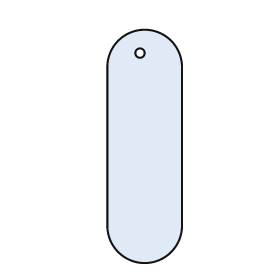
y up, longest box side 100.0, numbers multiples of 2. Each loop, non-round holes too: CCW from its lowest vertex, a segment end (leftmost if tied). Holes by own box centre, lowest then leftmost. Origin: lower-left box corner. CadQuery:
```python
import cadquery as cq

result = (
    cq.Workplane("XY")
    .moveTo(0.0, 16.0)
    .threePointArc((16.0, 0.0), (32.0, 16.0))
    .lineTo(32.0, 84.0)
    .threePointArc((16.0, 100.0), (0.0, 84.0))
    .close()
    .moveTo(14.0, 90.0)
    .circle(2.0)
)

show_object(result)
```